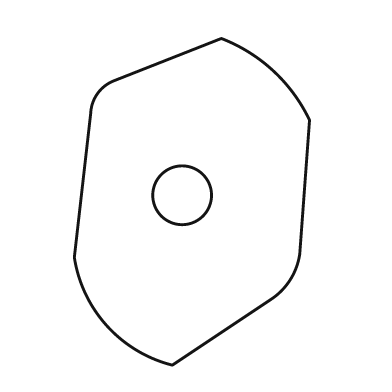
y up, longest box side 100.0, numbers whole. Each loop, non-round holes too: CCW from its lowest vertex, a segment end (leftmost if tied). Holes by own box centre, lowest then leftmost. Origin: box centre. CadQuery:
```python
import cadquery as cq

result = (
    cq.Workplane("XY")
    .moveTo(-6.0, -50.0)
    .lineTo(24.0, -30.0)
    .threePointArc((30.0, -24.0), (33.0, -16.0))
    .lineTo(36.0, 25.0)
    .threePointArc((25.0, 40.0), (9.0, 50.0))
    .lineTo(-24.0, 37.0)
    .threePointArc((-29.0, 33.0), (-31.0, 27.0))
    .lineTo(-36.0, -17.0)
    .threePointArc((-26.0, -38.0), (-6.0, -50.0))
    .close()
    .moveTo(-3.0, 2.0)
    .circle(9.0)
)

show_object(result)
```